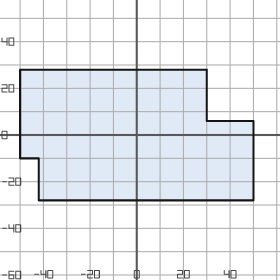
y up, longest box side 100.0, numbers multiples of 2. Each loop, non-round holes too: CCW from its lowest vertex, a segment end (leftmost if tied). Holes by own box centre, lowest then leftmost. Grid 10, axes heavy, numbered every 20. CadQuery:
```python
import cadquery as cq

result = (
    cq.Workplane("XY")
    .moveTo(-42.0, -28.0)
    .lineTo(50.0, -28.0)
    .lineTo(50.0, 6.0)
    .lineTo(30.0, 6.0)
    .lineTo(30.0, 28.0)
    .lineTo(-50.0, 28.0)
    .lineTo(-50.0, -10.0)
    .lineTo(-42.0, -10.0)
    .close()
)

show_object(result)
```